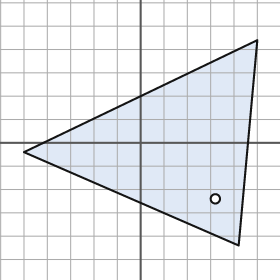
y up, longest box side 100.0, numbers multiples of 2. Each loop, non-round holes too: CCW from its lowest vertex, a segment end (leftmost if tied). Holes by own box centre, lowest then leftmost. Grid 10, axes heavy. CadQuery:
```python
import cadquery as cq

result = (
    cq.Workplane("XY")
    .moveTo(42.0, -44.0)
    .lineTo(50.0, 44.0)
    .lineTo(-50.0, -4.0)
    .close()
    .moveTo(32.0, -24.0)
    .circle(2.0)
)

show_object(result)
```